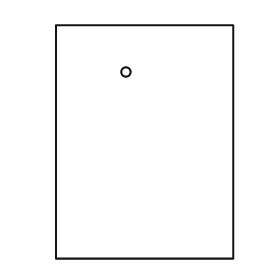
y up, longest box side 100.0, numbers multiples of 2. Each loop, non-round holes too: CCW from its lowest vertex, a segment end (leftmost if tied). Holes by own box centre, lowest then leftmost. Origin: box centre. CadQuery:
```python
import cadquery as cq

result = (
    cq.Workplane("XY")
    .moveTo(-38.0, -50.0)
    .lineTo(38.0, -50.0)
    .lineTo(38.0, 50.0)
    .lineTo(-38.0, 50.0)
    .close()
    .moveTo(-8.0, 30.0)
    .circle(2.0)
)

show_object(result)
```